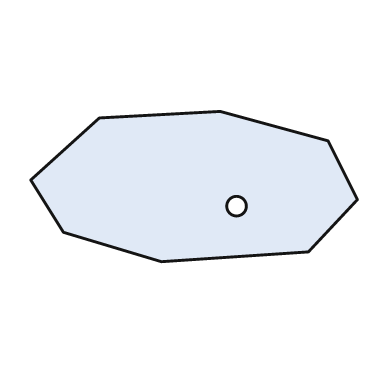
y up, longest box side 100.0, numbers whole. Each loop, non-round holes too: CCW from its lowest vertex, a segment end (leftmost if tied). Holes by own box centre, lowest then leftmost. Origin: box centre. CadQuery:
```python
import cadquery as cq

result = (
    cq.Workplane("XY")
    .moveTo(-10.0, -23.0)
    .lineTo(35.0, -20.0)
    .lineTo(50.0, -4.0)
    .lineTo(41.0, 14.0)
    .lineTo(8.0, 23.0)
    .lineTo(-29.0, 21.0)
    .lineTo(-50.0, 2.0)
    .lineTo(-40.0, -14.0)
    .close()
    .moveTo(13.0, -6.0)
    .circle(3.0)
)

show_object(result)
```